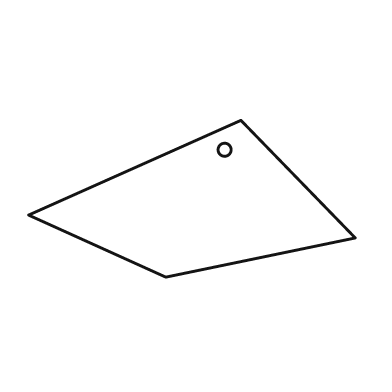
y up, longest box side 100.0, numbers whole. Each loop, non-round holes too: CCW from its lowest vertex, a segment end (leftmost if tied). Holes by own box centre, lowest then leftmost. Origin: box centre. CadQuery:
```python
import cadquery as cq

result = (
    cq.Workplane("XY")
    .moveTo(-8.0, -24.0)
    .lineTo(50.0, -12.0)
    .lineTo(15.0, 24.0)
    .lineTo(-50.0, -5.0)
    .close()
    .moveTo(10.0, 15.0)
    .circle(2.0)
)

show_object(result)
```